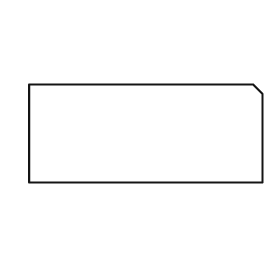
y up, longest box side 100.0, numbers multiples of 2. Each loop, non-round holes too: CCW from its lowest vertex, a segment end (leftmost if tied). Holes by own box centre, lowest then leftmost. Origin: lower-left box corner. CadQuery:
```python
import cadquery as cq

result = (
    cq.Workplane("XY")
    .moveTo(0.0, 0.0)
    .lineTo(100.0, 0.0)
    .lineTo(100.0, 38.0)
    .lineTo(96.0, 42.0)
    .lineTo(0.0, 42.0)
    .close()
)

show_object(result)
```